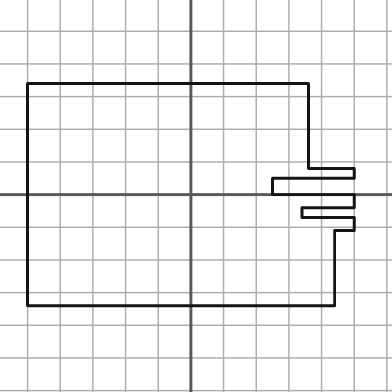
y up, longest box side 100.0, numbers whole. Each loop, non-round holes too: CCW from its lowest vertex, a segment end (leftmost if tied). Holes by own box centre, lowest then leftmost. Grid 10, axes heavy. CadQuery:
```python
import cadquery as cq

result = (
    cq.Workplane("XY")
    .moveTo(-50.0, -34.0)
    .lineTo(44.0, -34.0)
    .lineTo(44.0, -11.0)
    .lineTo(50.0, -11.0)
    .lineTo(50.0, -7.0)
    .lineTo(34.0, -7.0)
    .lineTo(34.0, -4.0)
    .lineTo(50.0, -4.0)
    .lineTo(50.0, 0.0)
    .lineTo(25.0, 0.0)
    .lineTo(25.0, 5.0)
    .lineTo(50.0, 5.0)
    .lineTo(50.0, 8.0)
    .lineTo(36.0, 8.0)
    .lineTo(36.0, 34.0)
    .lineTo(-50.0, 34.0)
    .close()
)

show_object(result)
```